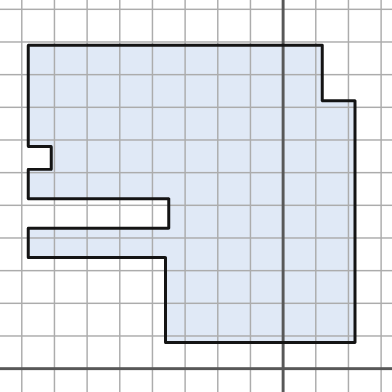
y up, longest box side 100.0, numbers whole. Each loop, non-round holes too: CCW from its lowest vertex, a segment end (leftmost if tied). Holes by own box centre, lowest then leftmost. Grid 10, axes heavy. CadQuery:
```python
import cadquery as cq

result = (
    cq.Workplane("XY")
    .moveTo(-36.0, 8.0)
    .lineTo(22.0, 8.0)
    .lineTo(22.0, 82.0)
    .lineTo(12.0, 82.0)
    .lineTo(12.0, 99.0)
    .lineTo(-78.0, 99.0)
    .lineTo(-78.0, 68.0)
    .lineTo(-71.0, 68.0)
    .lineTo(-71.0, 61.0)
    .lineTo(-78.0, 61.0)
    .lineTo(-78.0, 52.0)
    .lineTo(-35.0, 52.0)
    .lineTo(-35.0, 43.0)
    .lineTo(-78.0, 43.0)
    .lineTo(-78.0, 34.0)
    .lineTo(-36.0, 34.0)
    .close()
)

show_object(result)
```